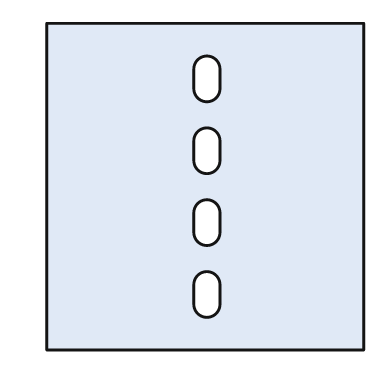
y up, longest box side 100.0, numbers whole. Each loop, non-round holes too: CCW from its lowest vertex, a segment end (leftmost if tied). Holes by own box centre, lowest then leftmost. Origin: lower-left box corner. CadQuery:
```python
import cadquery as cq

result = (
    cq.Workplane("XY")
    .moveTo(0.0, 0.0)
    .lineTo(97.0, 0.0)
    .lineTo(97.0, 100.0)
    .lineTo(0.0, 100.0)
    .close()
    .moveTo(45.0, 14.0)
    .threePointArc((49.0, 10.0), (53.0, 14.0))
    .lineTo(53.0, 20.0)
    .threePointArc((49.0, 24.0), (45.0, 20.0))
    .close()
    .moveTo(45.0, 36.0)
    .threePointArc((49.0, 32.0), (53.0, 36.0))
    .lineTo(53.0, 42.0)
    .threePointArc((49.0, 46.0), (45.0, 42.0))
    .close()
    .moveTo(45.0, 58.0)
    .threePointArc((49.0, 54.0), (53.0, 58.0))
    .lineTo(53.0, 64.0)
    .threePointArc((49.0, 68.0), (45.0, 64.0))
    .close()
    .moveTo(45.0, 80.0)
    .threePointArc((49.0, 76.0), (53.0, 80.0))
    .lineTo(53.0, 86.0)
    .threePointArc((49.0, 90.0), (45.0, 86.0))
    .close()
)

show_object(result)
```